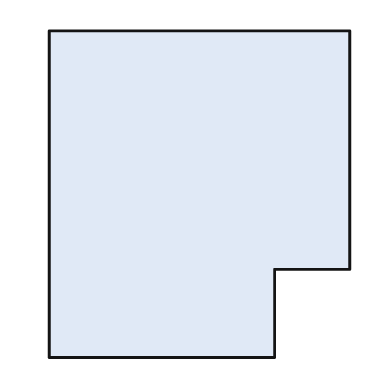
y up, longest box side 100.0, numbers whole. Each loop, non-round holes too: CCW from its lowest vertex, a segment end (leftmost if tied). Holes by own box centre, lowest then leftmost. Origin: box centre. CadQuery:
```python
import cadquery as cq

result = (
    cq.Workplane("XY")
    .moveTo(-46.0, -50.0)
    .lineTo(23.0, -50.0)
    .lineTo(23.0, -23.0)
    .lineTo(46.0, -23.0)
    .lineTo(46.0, 50.0)
    .lineTo(-46.0, 50.0)
    .close()
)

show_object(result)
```